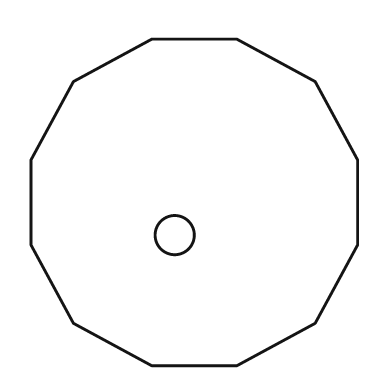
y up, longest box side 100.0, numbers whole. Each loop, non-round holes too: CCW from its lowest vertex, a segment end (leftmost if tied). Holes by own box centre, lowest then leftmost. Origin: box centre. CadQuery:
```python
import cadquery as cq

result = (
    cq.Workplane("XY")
    .moveTo(-13.0, -50.0)
    .lineTo(13.0, -50.0)
    .lineTo(37.0, -37.0)
    .lineTo(50.0, -13.0)
    .lineTo(50.0, 13.0)
    .lineTo(37.0, 37.0)
    .lineTo(13.0, 50.0)
    .lineTo(-13.0, 50.0)
    .lineTo(-37.0, 37.0)
    .lineTo(-50.0, 13.0)
    .lineTo(-50.0, -13.0)
    .lineTo(-37.0, -37.0)
    .close()
    .moveTo(-6.0, -10.0)
    .circle(6.0)
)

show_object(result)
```